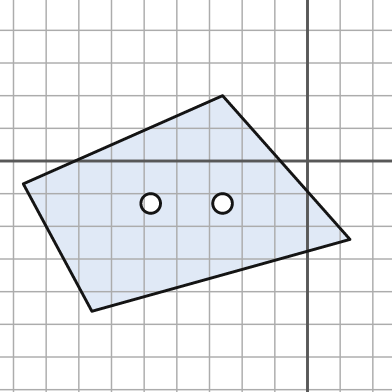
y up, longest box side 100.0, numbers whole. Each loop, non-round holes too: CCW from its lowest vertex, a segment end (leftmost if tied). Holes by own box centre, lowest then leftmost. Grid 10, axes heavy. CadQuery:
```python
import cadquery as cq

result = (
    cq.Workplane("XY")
    .moveTo(-66.0, -46.0)
    .lineTo(13.0, -24.0)
    .lineTo(-26.0, 20.0)
    .lineTo(-87.0, -7.0)
    .close()
    .moveTo(-48.0, -13.0)
    .circle(3.0)
    .moveTo(-26.0, -13.0)
    .circle(3.0)
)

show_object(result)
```